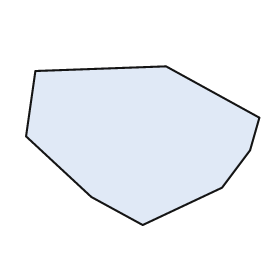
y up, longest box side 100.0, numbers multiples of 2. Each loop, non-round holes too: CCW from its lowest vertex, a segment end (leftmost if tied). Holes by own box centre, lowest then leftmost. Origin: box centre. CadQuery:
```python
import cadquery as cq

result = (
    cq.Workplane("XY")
    .moveTo(0.0, -34.0)
    .lineTo(34.0, -18.0)
    .lineTo(46.0, -2.0)
    .lineTo(50.0, 12.0)
    .lineTo(10.0, 34.0)
    .lineTo(-46.0, 32.0)
    .lineTo(-50.0, 4.0)
    .lineTo(-22.0, -22.0)
    .close()
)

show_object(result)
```